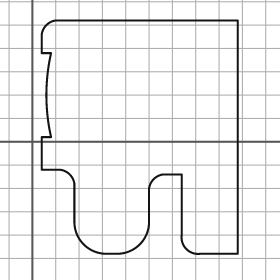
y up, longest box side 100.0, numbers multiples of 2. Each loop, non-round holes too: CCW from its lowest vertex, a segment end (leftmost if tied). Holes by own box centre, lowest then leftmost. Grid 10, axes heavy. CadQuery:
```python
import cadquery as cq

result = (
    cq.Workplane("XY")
    .moveTo(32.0, -48.0)
    .lineTo(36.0, -48.0)
    .threePointArc((46.0, -44.0), (50.0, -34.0))
    .lineTo(50.0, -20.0)
    .threePointArc((52.0, -16.0), (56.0, -14.0))
    .lineTo(64.0, -14.0)
    .lineTo(64.0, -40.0)
    .threePointArc((66.0, -46.0), (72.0, -48.0))
    .lineTo(88.0, -48.0)
    .lineTo(88.0, 52.0)
    .lineTo(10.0, 52.0)
    .threePointArc((6.0, 50.0), (4.0, 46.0))
    .lineTo(4.0, 38.0)
    .lineTo(8.0, 38.0)
    .threePointArc((6.0, 20.0), (8.0, 2.0))
    .lineTo(4.0, 2.0)
    .lineTo(4.0, -12.0)
    .lineTo(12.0, -12.0)
    .threePointArc((16.0, -14.0), (18.0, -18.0))
    .lineTo(18.0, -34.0)
    .threePointArc((22.0, -44.0), (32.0, -48.0))
    .close()
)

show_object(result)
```